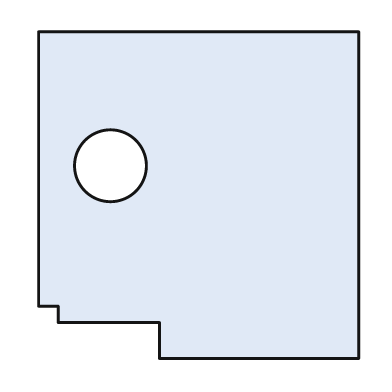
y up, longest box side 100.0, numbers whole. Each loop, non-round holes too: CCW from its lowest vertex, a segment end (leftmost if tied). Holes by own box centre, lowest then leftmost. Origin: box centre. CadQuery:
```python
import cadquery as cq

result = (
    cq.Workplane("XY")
    .moveTo(-12.0, -50.0)
    .lineTo(49.0, -50.0)
    .lineTo(49.0, 50.0)
    .lineTo(-49.0, 50.0)
    .lineTo(-49.0, -34.0)
    .lineTo(-43.0, -34.0)
    .lineTo(-43.0, -39.0)
    .lineTo(-12.0, -39.0)
    .close()
    .moveTo(-27.0, 9.0)
    .circle(11.0)
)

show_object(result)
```